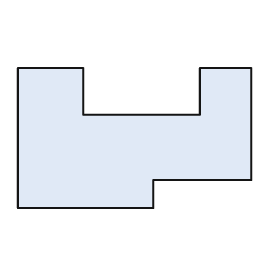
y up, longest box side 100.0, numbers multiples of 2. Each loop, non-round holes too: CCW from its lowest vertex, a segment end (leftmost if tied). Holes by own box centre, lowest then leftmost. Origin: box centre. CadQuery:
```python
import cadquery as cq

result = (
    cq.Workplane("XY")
    .moveTo(-50.0, -30.0)
    .lineTo(8.0, -30.0)
    .lineTo(8.0, -18.0)
    .lineTo(50.0, -18.0)
    .lineTo(50.0, 30.0)
    .lineTo(28.0, 30.0)
    .lineTo(28.0, 10.0)
    .lineTo(-22.0, 10.0)
    .lineTo(-22.0, 30.0)
    .lineTo(-50.0, 30.0)
    .close()
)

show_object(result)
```